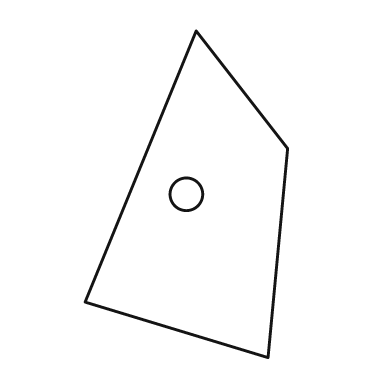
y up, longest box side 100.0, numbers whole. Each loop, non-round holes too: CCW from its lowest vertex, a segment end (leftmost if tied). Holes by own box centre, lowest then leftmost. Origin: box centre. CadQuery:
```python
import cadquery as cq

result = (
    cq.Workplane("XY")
    .moveTo(25.0, -50.0)
    .lineTo(31.0, 14.0)
    .lineTo(3.0, 50.0)
    .lineTo(-31.0, -33.0)
    .close()
    .moveTo(0.0, 0.0)
    .circle(5.0)
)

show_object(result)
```